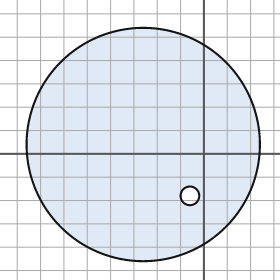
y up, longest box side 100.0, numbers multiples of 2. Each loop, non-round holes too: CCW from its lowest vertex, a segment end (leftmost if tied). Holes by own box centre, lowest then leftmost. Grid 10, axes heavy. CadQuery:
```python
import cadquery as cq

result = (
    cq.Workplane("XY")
    .moveTo(-26.0, 4.0)
    .circle(50.0)
    .moveTo(-6.0, -18.0)
    .circle(4.0)
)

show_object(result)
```